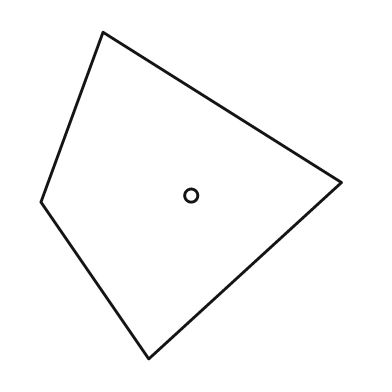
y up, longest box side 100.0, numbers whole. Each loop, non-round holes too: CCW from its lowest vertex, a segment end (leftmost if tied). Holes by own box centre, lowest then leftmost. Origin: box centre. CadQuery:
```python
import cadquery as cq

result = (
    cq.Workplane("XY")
    .moveTo(-13.0, -50.0)
    .lineTo(46.0, 4.0)
    .lineTo(-27.0, 50.0)
    .lineTo(-46.0, -2.0)
    .close()
    .moveTo(0.0, 0.0)
    .circle(2.0)
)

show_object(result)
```